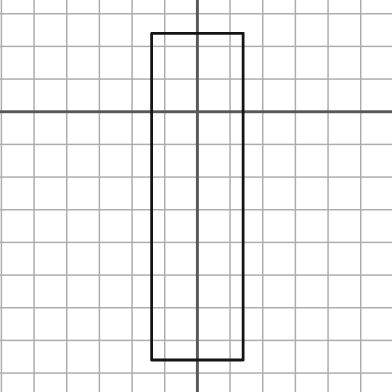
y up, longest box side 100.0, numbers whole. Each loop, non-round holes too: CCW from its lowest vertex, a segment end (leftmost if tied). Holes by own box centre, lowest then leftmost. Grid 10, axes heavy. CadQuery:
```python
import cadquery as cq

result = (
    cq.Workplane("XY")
    .moveTo(-14.0, -76.0)
    .lineTo(14.0, -76.0)
    .lineTo(14.0, 24.0)
    .lineTo(-14.0, 24.0)
    .close()
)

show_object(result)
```